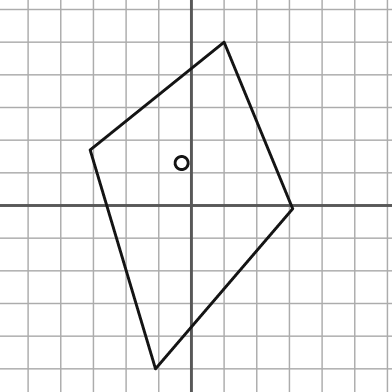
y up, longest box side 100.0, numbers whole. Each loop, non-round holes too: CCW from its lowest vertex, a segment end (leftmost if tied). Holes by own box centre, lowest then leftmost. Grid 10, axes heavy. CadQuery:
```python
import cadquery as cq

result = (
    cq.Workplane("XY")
    .moveTo(-11.0, -50.0)
    .lineTo(31.0, -1.0)
    .lineTo(10.0, 50.0)
    .lineTo(-31.0, 17.0)
    .close()
    .moveTo(-3.0, 13.0)
    .circle(2.0)
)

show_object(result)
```